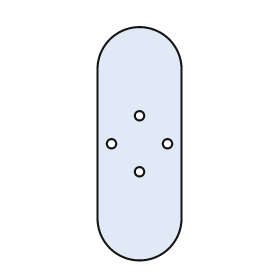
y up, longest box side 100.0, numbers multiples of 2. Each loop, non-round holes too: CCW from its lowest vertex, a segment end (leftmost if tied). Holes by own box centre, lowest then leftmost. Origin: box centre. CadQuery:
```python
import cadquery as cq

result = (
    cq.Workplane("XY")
    .moveTo(-18.0, -32.0)
    .threePointArc((0.0, -50.0), (18.0, -32.0))
    .lineTo(18.0, 32.0)
    .threePointArc((0.0, 50.0), (-18.0, 32.0))
    .close()
    .moveTo(0.0, -12.0)
    .circle(2.0)
    .moveTo(-12.0, 0.0)
    .circle(2.0)
    .moveTo(12.0, 0.0)
    .circle(2.0)
    .moveTo(0.0, 12.0)
    .circle(2.0)
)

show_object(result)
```